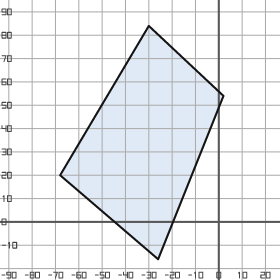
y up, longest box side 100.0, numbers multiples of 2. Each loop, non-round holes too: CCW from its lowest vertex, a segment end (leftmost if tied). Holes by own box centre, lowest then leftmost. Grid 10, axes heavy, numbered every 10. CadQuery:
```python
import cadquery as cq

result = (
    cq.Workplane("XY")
    .moveTo(-26.0, -16.0)
    .lineTo(2.0, 54.0)
    .lineTo(-30.0, 84.0)
    .lineTo(-68.0, 20.0)
    .close()
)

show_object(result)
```